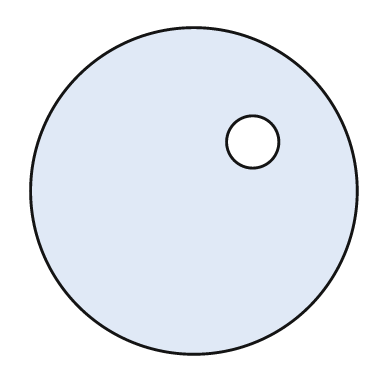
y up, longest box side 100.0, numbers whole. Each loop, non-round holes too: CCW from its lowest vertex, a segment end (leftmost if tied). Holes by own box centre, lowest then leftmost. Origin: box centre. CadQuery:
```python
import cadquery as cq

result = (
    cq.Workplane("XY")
    .moveTo(0.0, 0.0)
    .circle(50.0)
    .moveTo(18.0, 15.0)
    .circle(8.0)
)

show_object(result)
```